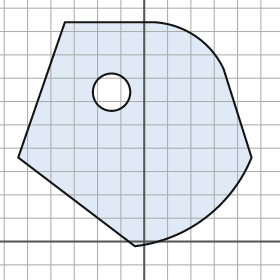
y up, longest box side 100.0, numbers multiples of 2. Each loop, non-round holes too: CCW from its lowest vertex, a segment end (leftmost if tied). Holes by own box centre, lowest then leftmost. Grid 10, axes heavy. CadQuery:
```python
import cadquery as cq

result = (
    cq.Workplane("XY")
    .moveTo(-4.0, -2.0)
    .threePointArc((26.0, 10.0), (46.0, 36.0))
    .lineTo(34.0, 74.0)
    .threePointArc((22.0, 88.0), (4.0, 94.0))
    .lineTo(-34.0, 94.0)
    .lineTo(-54.0, 36.0)
    .close()
    .moveTo(-14.0, 64.0)
    .circle(8.0)
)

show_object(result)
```